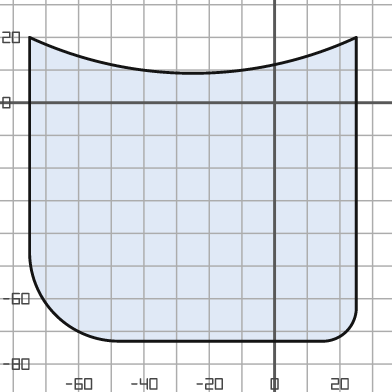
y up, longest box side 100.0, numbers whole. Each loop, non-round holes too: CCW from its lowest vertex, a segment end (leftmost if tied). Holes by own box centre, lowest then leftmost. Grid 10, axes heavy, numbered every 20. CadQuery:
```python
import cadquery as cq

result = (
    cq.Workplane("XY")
    .moveTo(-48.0, -73.0)
    .lineTo(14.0, -73.0)
    .threePointArc((22.0, -70.0), (25.0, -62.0))
    .lineTo(25.0, 20.0)
    .threePointArc((-25.0, 9.0), (-75.0, 20.0))
    .lineTo(-75.0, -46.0)
    .threePointArc((-67.0, -65.0), (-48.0, -73.0))
    .close()
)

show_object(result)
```